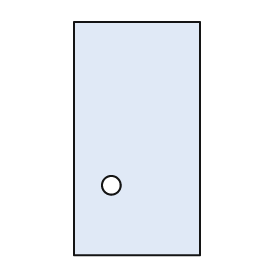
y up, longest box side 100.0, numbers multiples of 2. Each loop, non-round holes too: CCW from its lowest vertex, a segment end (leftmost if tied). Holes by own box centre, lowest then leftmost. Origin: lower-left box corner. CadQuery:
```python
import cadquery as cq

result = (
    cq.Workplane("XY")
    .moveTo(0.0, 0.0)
    .lineTo(54.0, 0.0)
    .lineTo(54.0, 100.0)
    .lineTo(0.0, 100.0)
    .close()
    .moveTo(16.0, 30.0)
    .circle(4.0)
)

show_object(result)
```